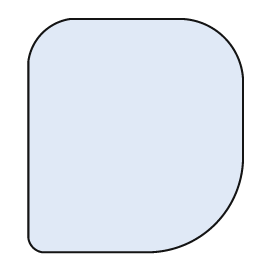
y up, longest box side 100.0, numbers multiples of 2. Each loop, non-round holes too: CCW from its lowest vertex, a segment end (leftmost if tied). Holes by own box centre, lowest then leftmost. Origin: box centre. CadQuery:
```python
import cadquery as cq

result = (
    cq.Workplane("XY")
    .moveTo(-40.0, -50.0)
    .lineTo(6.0, -50.0)
    .threePointArc((34.0, -38.0), (46.0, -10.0))
    .lineTo(46.0, 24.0)
    .threePointArc((38.0, 42.0), (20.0, 50.0))
    .lineTo(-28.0, 50.0)
    .threePointArc((-40.0, 44.0), (-46.0, 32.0))
    .lineTo(-46.0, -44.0)
    .threePointArc((-44.0, -48.0), (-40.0, -50.0))
    .close()
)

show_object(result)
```